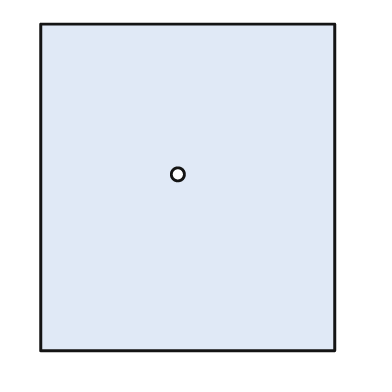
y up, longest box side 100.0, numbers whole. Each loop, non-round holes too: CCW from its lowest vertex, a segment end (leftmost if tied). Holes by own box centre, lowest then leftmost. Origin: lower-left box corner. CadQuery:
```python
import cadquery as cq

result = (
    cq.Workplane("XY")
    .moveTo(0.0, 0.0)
    .lineTo(90.0, 0.0)
    .lineTo(90.0, 100.0)
    .lineTo(0.0, 100.0)
    .close()
    .moveTo(42.0, 54.0)
    .circle(2.0)
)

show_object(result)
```